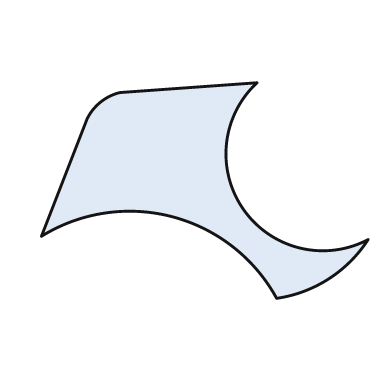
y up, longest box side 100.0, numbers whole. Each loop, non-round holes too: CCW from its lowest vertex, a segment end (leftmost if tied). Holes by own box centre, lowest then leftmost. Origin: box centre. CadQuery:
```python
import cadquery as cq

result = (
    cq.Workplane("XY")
    .moveTo(22.0, -33.0)
    .threePointArc((38.0, -27.0), (50.0, -15.0))
    .threePointArc((12.0, -6.0), (16.0, 33.0))
    .lineTo(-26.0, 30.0)
    .threePointArc((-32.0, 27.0), (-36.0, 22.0))
    .lineTo(-50.0, -14.0)
    .threePointArc((-10.0, -8.0), (22.0, -33.0))
    .close()
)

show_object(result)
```